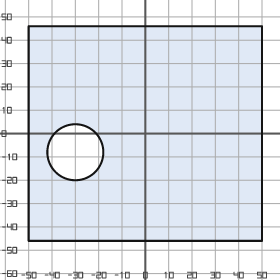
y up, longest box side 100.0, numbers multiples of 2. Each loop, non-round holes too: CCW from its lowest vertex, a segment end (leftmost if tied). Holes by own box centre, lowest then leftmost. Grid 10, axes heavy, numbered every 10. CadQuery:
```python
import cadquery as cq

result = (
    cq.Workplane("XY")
    .moveTo(-50.0, -46.0)
    .lineTo(50.0, -46.0)
    .lineTo(50.0, 46.0)
    .lineTo(-50.0, 46.0)
    .close()
    .moveTo(-30.0, -8.0)
    .circle(12.0)
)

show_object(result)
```